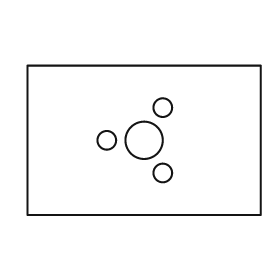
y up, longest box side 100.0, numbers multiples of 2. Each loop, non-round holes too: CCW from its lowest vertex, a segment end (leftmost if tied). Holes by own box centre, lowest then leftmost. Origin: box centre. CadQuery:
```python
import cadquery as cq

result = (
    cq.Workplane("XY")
    .moveTo(-50.0, -32.0)
    .lineTo(50.0, -32.0)
    .lineTo(50.0, 32.0)
    .lineTo(-50.0, 32.0)
    .close()
    .moveTo(8.0, -14.0)
    .circle(4.0)
    .moveTo(-16.0, 0.0)
    .circle(4.0)
    .moveTo(0.0, 0.0)
    .circle(8.0)
    .moveTo(8.0, 14.0)
    .circle(4.0)
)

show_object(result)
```